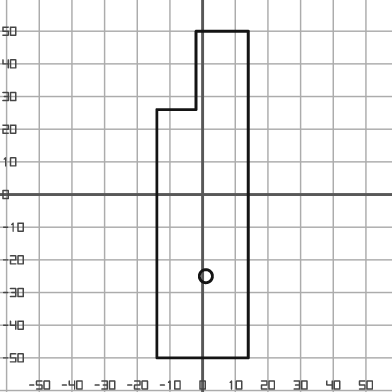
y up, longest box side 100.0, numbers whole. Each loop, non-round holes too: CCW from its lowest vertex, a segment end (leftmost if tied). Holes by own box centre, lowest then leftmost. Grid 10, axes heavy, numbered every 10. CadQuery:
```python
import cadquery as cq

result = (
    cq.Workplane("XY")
    .moveTo(-14.0, -50.0)
    .lineTo(14.0, -50.0)
    .lineTo(14.0, 50.0)
    .lineTo(-2.0, 50.0)
    .lineTo(-2.0, 26.0)
    .lineTo(-14.0, 26.0)
    .close()
    .moveTo(1.0, -25.0)
    .circle(2.0)
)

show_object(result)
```